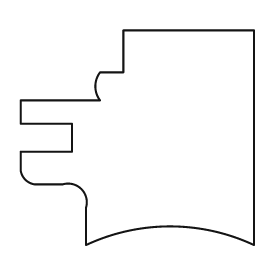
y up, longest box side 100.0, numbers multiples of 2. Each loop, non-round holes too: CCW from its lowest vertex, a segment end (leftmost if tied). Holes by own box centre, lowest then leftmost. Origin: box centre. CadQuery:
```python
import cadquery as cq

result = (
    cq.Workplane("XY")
    .moveTo(-22.0, -46.0)
    .threePointArc((14.0, -38.0), (50.0, -46.0))
    .lineTo(50.0, 46.0)
    .lineTo(-6.0, 46.0)
    .lineTo(-6.0, 28.0)
    .lineTo(-16.0, 28.0)
    .threePointArc((-18.0, 22.0), (-16.0, 16.0))
    .lineTo(-50.0, 16.0)
    .lineTo(-50.0, 6.0)
    .lineTo(-28.0, 6.0)
    .lineTo(-28.0, -6.0)
    .lineTo(-50.0, -6.0)
    .lineTo(-50.0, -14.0)
    .threePointArc((-48.0, -18.0), (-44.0, -20.0))
    .lineTo(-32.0, -20.0)
    .threePointArc((-24.0, -22.0), (-22.0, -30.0))
    .close()
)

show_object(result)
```